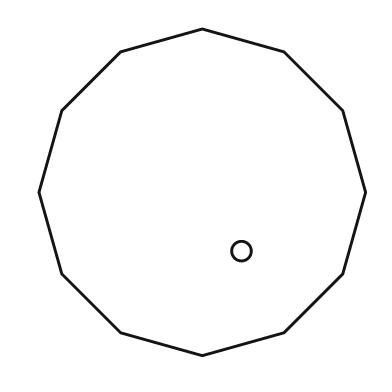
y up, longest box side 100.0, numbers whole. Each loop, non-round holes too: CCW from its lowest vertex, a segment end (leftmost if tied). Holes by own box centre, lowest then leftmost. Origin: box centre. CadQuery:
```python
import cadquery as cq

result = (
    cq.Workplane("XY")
    .moveTo(0.0, -50.0)
    .lineTo(25.0, -43.0)
    .lineTo(43.0, -25.0)
    .lineTo(50.0, 0.0)
    .lineTo(43.0, 25.0)
    .lineTo(25.0, 43.0)
    .lineTo(0.0, 50.0)
    .lineTo(-25.0, 43.0)
    .lineTo(-43.0, 25.0)
    .lineTo(-50.0, 0.0)
    .lineTo(-43.0, -25.0)
    .lineTo(-25.0, -43.0)
    .close()
    .moveTo(12.0, -18.0)
    .circle(3.0)
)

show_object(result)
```